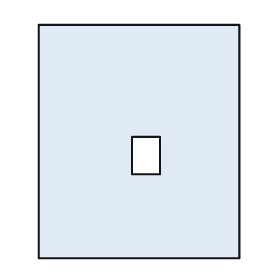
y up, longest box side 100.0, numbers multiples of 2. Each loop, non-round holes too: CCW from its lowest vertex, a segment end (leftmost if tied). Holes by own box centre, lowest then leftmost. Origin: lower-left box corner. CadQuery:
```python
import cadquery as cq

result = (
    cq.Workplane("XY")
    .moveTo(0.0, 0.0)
    .lineTo(86.0, 0.0)
    .lineTo(86.0, 100.0)
    .lineTo(0.0, 100.0)
    .close()
    .moveTo(40.0, 36.0)
    .lineTo(52.0, 36.0)
    .lineTo(52.0, 52.0)
    .lineTo(40.0, 52.0)
    .close()
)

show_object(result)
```